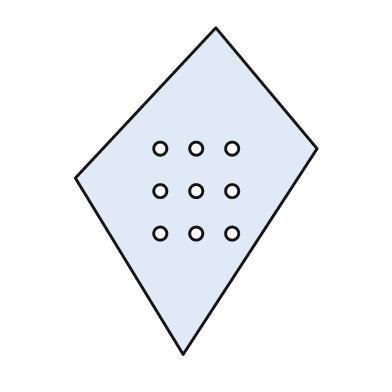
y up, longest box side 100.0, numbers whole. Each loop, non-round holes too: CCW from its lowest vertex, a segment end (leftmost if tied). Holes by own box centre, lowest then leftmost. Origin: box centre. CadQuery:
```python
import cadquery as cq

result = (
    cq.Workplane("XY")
    .moveTo(-4.0, -50.0)
    .lineTo(37.0, 13.0)
    .lineTo(6.0, 50.0)
    .lineTo(-37.0, 4.0)
    .close()
    .moveTo(-11.0, -13.0)
    .circle(2.0)
    .moveTo(0.0, -13.0)
    .circle(2.0)
    .moveTo(11.0, -13.0)
    .circle(2.0)
    .moveTo(-11.0, 0.0)
    .circle(2.0)
    .moveTo(0.0, 0.0)
    .circle(2.0)
    .moveTo(11.0, 0.0)
    .circle(2.0)
    .moveTo(-11.0, 13.0)
    .circle(2.0)
    .moveTo(0.0, 13.0)
    .circle(2.0)
    .moveTo(11.0, 13.0)
    .circle(2.0)
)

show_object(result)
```